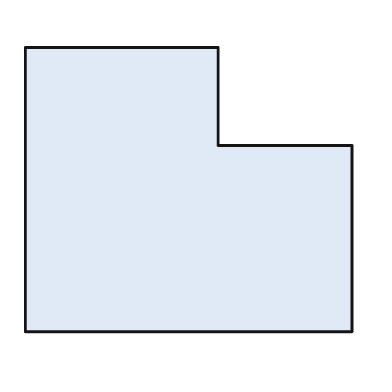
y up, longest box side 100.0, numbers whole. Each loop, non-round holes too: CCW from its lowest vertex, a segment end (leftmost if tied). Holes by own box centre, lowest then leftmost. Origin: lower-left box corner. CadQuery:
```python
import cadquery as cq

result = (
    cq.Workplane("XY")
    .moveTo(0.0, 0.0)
    .lineTo(100.0, 0.0)
    .lineTo(100.0, 57.0)
    .lineTo(59.0, 57.0)
    .lineTo(59.0, 87.0)
    .lineTo(0.0, 87.0)
    .close()
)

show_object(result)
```